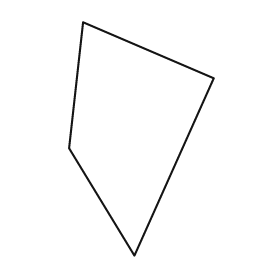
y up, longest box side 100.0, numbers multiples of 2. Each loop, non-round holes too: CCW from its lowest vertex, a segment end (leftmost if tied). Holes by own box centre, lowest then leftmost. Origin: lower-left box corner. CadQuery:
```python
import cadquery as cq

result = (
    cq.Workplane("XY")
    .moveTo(28.0, 0.0)
    .lineTo(62.0, 76.0)
    .lineTo(6.0, 100.0)
    .lineTo(0.0, 46.0)
    .close()
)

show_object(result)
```